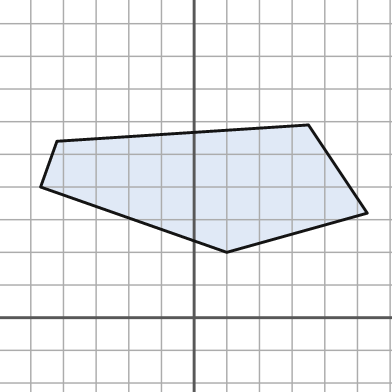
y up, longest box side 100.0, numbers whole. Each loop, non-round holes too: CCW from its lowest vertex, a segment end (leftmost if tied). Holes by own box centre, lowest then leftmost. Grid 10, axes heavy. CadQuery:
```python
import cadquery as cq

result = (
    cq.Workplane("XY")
    .moveTo(10.0, 20.0)
    .lineTo(53.0, 32.0)
    .lineTo(35.0, 59.0)
    .lineTo(-42.0, 54.0)
    .lineTo(-47.0, 40.0)
    .close()
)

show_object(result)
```